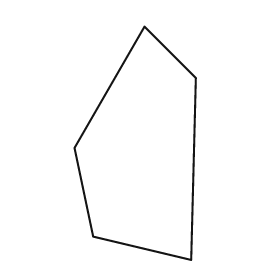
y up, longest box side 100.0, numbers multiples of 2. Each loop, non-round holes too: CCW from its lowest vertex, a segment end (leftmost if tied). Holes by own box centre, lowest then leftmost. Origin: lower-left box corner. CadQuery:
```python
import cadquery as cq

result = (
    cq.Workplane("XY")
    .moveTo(50.0, 0.0)
    .lineTo(52.0, 78.0)
    .lineTo(30.0, 100.0)
    .lineTo(0.0, 48.0)
    .lineTo(8.0, 10.0)
    .close()
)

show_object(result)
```